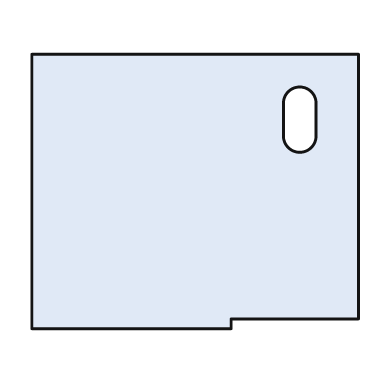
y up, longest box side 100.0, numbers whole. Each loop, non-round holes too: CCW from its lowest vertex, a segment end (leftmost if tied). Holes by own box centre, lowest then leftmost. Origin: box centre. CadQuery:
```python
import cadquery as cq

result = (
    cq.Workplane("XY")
    .moveTo(-50.0, -42.0)
    .lineTo(11.0, -42.0)
    .lineTo(11.0, -39.0)
    .lineTo(50.0, -39.0)
    .lineTo(50.0, 42.0)
    .lineTo(-50.0, 42.0)
    .close()
    .moveTo(27.0, 17.0)
    .threePointArc((32.0, 12.0), (37.0, 17.0))
    .lineTo(37.0, 27.0)
    .threePointArc((32.0, 32.0), (27.0, 27.0))
    .close()
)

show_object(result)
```